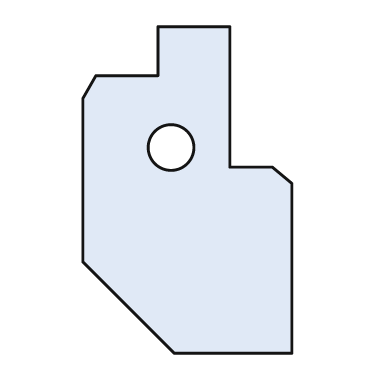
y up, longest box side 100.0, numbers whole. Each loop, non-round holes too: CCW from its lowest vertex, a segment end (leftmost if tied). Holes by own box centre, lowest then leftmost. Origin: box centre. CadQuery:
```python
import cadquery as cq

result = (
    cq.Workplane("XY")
    .moveTo(-4.0, -50.0)
    .lineTo(32.0, -50.0)
    .lineTo(32.0, 2.0)
    .lineTo(26.0, 7.0)
    .lineTo(13.0, 7.0)
    .lineTo(13.0, 50.0)
    .lineTo(-9.0, 50.0)
    .lineTo(-9.0, 35.0)
    .lineTo(-28.0, 35.0)
    .lineTo(-32.0, 28.0)
    .lineTo(-32.0, -22.0)
    .close()
    .moveTo(-5.0, 13.0)
    .circle(7.0)
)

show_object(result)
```